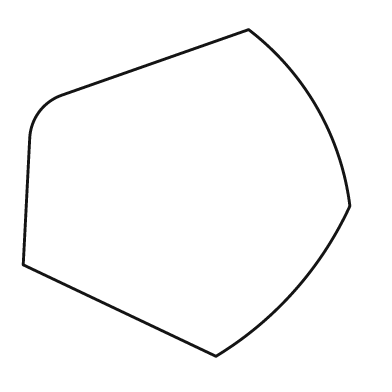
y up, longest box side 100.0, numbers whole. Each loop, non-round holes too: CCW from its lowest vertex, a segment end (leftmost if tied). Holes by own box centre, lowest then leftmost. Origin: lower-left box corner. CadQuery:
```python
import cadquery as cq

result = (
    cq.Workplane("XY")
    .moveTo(59.0, 0.0)
    .threePointArc((83.0, 20.0), (100.0, 46.0))
    .threePointArc((90.0, 76.0), (69.0, 100.0))
    .lineTo(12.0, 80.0)
    .threePointArc((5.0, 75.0), (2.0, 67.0))
    .lineTo(0.0, 28.0)
    .close()
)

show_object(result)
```